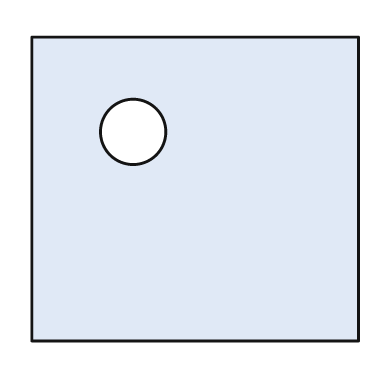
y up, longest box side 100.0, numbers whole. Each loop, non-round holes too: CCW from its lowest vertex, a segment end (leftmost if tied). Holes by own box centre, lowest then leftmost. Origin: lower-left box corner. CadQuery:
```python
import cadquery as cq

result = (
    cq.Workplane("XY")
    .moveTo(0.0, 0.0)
    .lineTo(100.0, 0.0)
    .lineTo(100.0, 93.0)
    .lineTo(0.0, 93.0)
    .close()
    .moveTo(31.0, 64.0)
    .circle(10.0)
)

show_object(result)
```